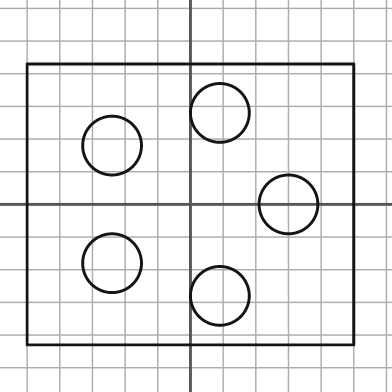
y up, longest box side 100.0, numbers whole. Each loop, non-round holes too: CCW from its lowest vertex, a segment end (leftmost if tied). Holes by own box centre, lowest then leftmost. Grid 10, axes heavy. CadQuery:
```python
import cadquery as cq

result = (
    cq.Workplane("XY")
    .moveTo(-50.0, -43.0)
    .lineTo(50.0, -43.0)
    .lineTo(50.0, 43.0)
    .lineTo(-50.0, 43.0)
    .close()
    .moveTo(9.0, -28.0)
    .circle(9.0)
    .moveTo(-24.0, -18.0)
    .circle(9.0)
    .moveTo(30.0, 0.0)
    .circle(9.0)
    .moveTo(-24.0, 18.0)
    .circle(9.0)
    .moveTo(9.0, 28.0)
    .circle(9.0)
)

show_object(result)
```